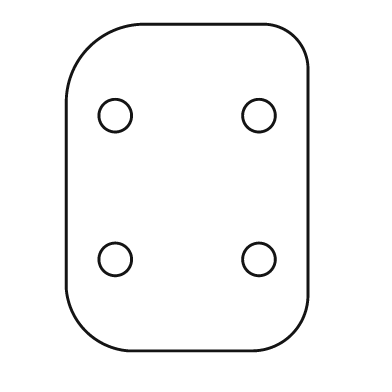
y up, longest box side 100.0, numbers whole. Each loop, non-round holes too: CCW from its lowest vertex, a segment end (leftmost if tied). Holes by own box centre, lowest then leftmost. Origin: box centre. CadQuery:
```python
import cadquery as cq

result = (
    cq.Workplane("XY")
    .moveTo(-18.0, -50.0)
    .lineTo(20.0, -50.0)
    .threePointArc((32.0, -45.0), (37.0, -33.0))
    .lineTo(37.0, 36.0)
    .threePointArc((33.0, 46.0), (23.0, 50.0))
    .lineTo(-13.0, 50.0)
    .threePointArc((-30.0, 43.0), (-37.0, 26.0))
    .lineTo(-37.0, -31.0)
    .threePointArc((-31.0, -44.0), (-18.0, -50.0))
    .close()
    .moveTo(-22.0, -22.0)
    .circle(5.0)
    .moveTo(22.0, -22.0)
    .circle(5.0)
    .moveTo(-22.0, 22.0)
    .circle(5.0)
    .moveTo(22.0, 22.0)
    .circle(5.0)
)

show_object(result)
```